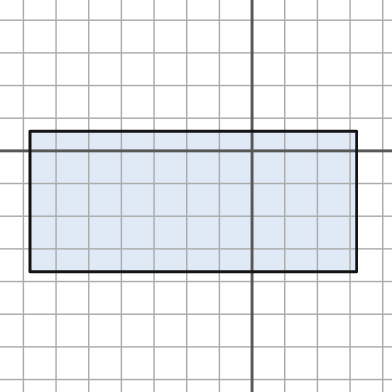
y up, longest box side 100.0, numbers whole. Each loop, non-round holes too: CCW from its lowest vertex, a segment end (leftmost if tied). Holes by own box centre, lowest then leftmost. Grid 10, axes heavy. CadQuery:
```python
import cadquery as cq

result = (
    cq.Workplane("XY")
    .moveTo(-68.0, -37.0)
    .lineTo(32.0, -37.0)
    .lineTo(32.0, 6.0)
    .lineTo(-68.0, 6.0)
    .close()
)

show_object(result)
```